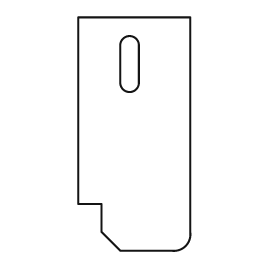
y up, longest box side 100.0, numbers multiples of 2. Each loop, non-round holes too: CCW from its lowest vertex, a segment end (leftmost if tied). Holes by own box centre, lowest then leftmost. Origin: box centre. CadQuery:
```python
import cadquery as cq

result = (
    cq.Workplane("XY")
    .moveTo(-6.0, -50.0)
    .lineTo(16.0, -50.0)
    .threePointArc((22.0, -48.0), (24.0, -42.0))
    .lineTo(24.0, 50.0)
    .lineTo(-24.0, 50.0)
    .lineTo(-24.0, -30.0)
    .lineTo(-14.0, -30.0)
    .lineTo(-14.0, -42.0)
    .close()
    .moveTo(-6.0, 22.0)
    .threePointArc((-2.0, 18.0), (2.0, 22.0))
    .lineTo(2.0, 38.0)
    .threePointArc((-2.0, 42.0), (-6.0, 38.0))
    .close()
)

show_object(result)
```